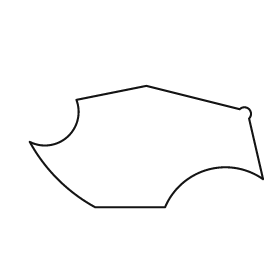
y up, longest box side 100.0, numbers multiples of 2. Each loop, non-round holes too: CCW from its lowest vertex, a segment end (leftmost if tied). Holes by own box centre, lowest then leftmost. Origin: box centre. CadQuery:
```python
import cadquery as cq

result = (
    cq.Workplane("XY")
    .moveTo(-22.0, -26.0)
    .lineTo(8.0, -26.0)
    .threePointArc((26.0, -10.0), (50.0, -14.0))
    .lineTo(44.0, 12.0)
    .threePointArc((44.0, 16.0), (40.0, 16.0))
    .lineTo(0.0, 26.0)
    .lineTo(-30.0, 20.0)
    .threePointArc((-34.0, 4.0), (-50.0, 2.0))
    .threePointArc((-38.0, -14.0), (-22.0, -26.0))
    .close()
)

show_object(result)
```